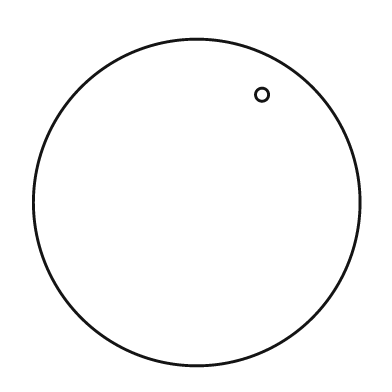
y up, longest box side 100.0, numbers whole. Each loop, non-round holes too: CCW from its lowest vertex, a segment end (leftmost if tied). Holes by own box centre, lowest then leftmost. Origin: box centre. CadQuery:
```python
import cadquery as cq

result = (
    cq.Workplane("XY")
    .moveTo(0.0, 0.0)
    .circle(50.0)
    .moveTo(20.0, 33.0)
    .circle(2.0)
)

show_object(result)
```